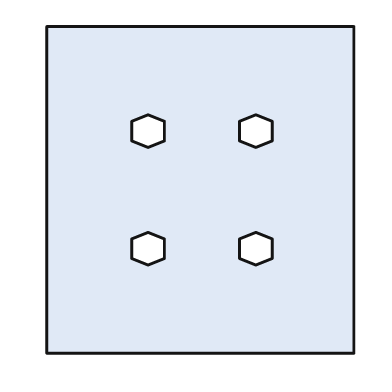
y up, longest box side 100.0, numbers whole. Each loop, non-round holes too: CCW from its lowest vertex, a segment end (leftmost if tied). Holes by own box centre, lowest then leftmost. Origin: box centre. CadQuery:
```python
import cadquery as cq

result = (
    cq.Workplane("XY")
    .moveTo(-47.0, -50.0)
    .lineTo(47.0, -50.0)
    .lineTo(47.0, 50.0)
    .lineTo(-47.0, 50.0)
    .close()
    .moveTo(-16.0, -23.0)
    .lineTo(-11.0, -21.0)
    .lineTo(-11.0, -15.0)
    .lineTo(-16.0, -13.0)
    .lineTo(-21.0, -15.0)
    .lineTo(-21.0, -21.0)
    .close()
    .moveTo(17.0, -23.0)
    .lineTo(22.0, -21.0)
    .lineTo(22.0, -15.0)
    .lineTo(17.0, -13.0)
    .lineTo(12.0, -15.0)
    .lineTo(12.0, -21.0)
    .close()
    .moveTo(-16.0, 13.0)
    .lineTo(-11.0, 15.0)
    .lineTo(-11.0, 21.0)
    .lineTo(-16.0, 23.0)
    .lineTo(-21.0, 21.0)
    .lineTo(-21.0, 15.0)
    .close()
    .moveTo(17.0, 13.0)
    .lineTo(22.0, 15.0)
    .lineTo(22.0, 21.0)
    .lineTo(17.0, 23.0)
    .lineTo(12.0, 21.0)
    .lineTo(12.0, 15.0)
    .close()
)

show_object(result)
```